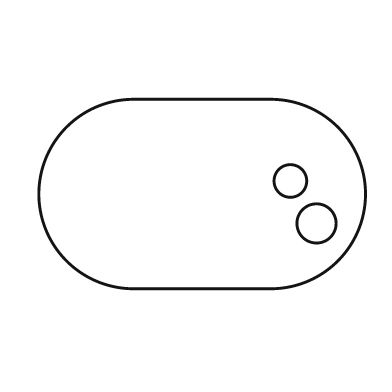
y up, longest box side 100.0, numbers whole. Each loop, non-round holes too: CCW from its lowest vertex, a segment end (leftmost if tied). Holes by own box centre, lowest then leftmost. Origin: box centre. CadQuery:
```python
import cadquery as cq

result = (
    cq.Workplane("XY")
    .moveTo(-21.0, -29.0)
    .lineTo(21.0, -29.0)
    .threePointArc((50.0, 0.0), (21.0, 29.0))
    .lineTo(-21.0, 29.0)
    .threePointArc((-50.0, 0.0), (-21.0, -29.0))
    .close()
    .moveTo(35.0, -9.0)
    .circle(6.0)
    .moveTo(27.0, 4.0)
    .circle(5.0)
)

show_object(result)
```